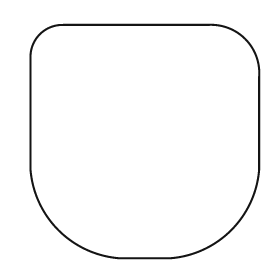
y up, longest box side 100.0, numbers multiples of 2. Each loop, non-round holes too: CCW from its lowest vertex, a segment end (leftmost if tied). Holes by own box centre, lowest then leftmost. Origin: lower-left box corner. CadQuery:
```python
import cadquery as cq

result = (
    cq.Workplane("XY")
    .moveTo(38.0, 0.0)
    .lineTo(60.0, 0.0)
    .threePointArc((86.0, 12.0), (98.0, 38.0))
    .lineTo(98.0, 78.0)
    .threePointArc((92.0, 94.0), (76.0, 100.0))
    .lineTo(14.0, 100.0)
    .threePointArc((4.0, 96.0), (0.0, 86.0))
    .lineTo(0.0, 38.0)
    .threePointArc((12.0, 12.0), (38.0, 0.0))
    .close()
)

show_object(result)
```